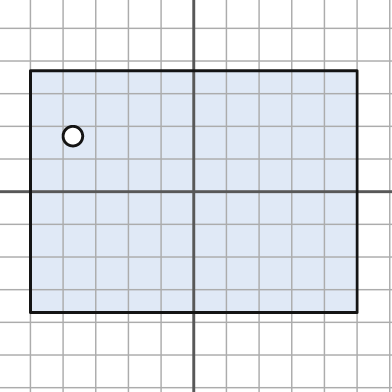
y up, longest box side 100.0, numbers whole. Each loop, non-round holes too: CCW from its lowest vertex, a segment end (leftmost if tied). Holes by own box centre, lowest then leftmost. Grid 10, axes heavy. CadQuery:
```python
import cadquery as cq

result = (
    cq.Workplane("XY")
    .moveTo(-50.0, -37.0)
    .lineTo(50.0, -37.0)
    .lineTo(50.0, 37.0)
    .lineTo(-50.0, 37.0)
    .close()
    .moveTo(-37.0, 17.0)
    .circle(3.0)
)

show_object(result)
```